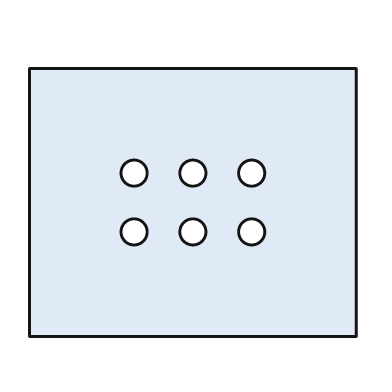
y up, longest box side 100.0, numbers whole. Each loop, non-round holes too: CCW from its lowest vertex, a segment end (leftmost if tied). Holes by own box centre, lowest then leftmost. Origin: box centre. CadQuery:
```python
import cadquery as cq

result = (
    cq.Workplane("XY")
    .moveTo(-50.0, -41.0)
    .lineTo(50.0, -41.0)
    .lineTo(50.0, 41.0)
    .lineTo(-50.0, 41.0)
    .close()
    .moveTo(-18.0, -9.0)
    .circle(4.0)
    .moveTo(0.0, -9.0)
    .circle(4.0)
    .moveTo(18.0, -9.0)
    .circle(4.0)
    .moveTo(-18.0, 9.0)
    .circle(4.0)
    .moveTo(0.0, 9.0)
    .circle(4.0)
    .moveTo(18.0, 9.0)
    .circle(4.0)
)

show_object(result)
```